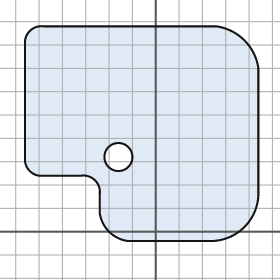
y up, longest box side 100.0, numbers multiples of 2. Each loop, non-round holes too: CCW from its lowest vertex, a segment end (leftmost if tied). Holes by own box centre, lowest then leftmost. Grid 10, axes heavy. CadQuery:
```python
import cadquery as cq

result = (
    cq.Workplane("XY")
    .moveTo(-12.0, -4.0)
    .lineTo(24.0, -4.0)
    .threePointArc((38.0, 2.0), (44.0, 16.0))
    .lineTo(44.0, 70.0)
    .threePointArc((38.0, 82.0), (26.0, 88.0))
    .lineTo(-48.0, 88.0)
    .threePointArc((-54.0, 86.0), (-56.0, 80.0))
    .lineTo(-56.0, 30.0)
    .threePointArc((-54.0, 26.0), (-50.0, 24.0))
    .lineTo(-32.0, 24.0)
    .threePointArc((-26.0, 22.0), (-24.0, 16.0))
    .lineTo(-24.0, 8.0)
    .threePointArc((-20.0, 0.0), (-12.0, -4.0))
    .close()
    .moveTo(-16.0, 32.0)
    .circle(6.0)
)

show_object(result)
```